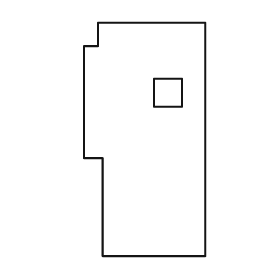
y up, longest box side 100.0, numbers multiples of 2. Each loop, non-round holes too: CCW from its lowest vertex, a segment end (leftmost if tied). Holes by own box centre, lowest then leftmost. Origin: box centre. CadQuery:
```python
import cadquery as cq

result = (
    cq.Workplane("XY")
    .moveTo(-18.0, -50.0)
    .lineTo(26.0, -50.0)
    .lineTo(26.0, 50.0)
    .lineTo(-20.0, 50.0)
    .lineTo(-20.0, 40.0)
    .lineTo(-26.0, 40.0)
    .lineTo(-26.0, -8.0)
    .lineTo(-18.0, -8.0)
    .close()
    .moveTo(4.0, 14.0)
    .lineTo(16.0, 14.0)
    .lineTo(16.0, 26.0)
    .lineTo(4.0, 26.0)
    .close()
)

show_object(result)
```